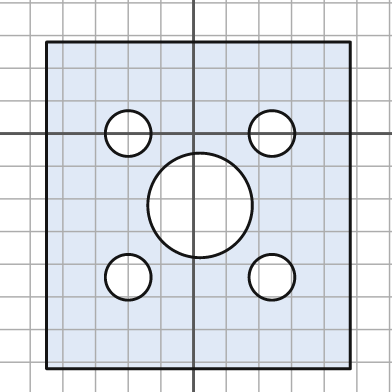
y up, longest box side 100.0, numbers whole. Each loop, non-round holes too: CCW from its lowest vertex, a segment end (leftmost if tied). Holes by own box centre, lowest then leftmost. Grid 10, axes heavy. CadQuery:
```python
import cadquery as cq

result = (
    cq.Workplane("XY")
    .moveTo(-45.0, -72.0)
    .lineTo(48.0, -72.0)
    .lineTo(48.0, 28.0)
    .lineTo(-45.0, 28.0)
    .close()
    .moveTo(-20.0, -44.0)
    .circle(7.0)
    .moveTo(24.0, -44.0)
    .circle(7.0)
    .moveTo(2.0, -22.0)
    .circle(16.0)
    .moveTo(-20.0, 0.0)
    .circle(7.0)
    .moveTo(24.0, 0.0)
    .circle(7.0)
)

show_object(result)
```